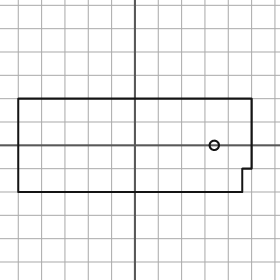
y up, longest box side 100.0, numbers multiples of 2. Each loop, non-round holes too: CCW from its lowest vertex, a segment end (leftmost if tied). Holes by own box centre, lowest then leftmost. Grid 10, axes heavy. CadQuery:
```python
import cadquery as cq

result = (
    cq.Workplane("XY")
    .moveTo(-50.0, -20.0)
    .lineTo(46.0, -20.0)
    .lineTo(46.0, -10.0)
    .lineTo(50.0, -10.0)
    .lineTo(50.0, 20.0)
    .lineTo(-50.0, 20.0)
    .close()
    .moveTo(34.0, 0.0)
    .circle(2.0)
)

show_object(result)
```